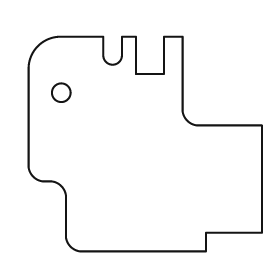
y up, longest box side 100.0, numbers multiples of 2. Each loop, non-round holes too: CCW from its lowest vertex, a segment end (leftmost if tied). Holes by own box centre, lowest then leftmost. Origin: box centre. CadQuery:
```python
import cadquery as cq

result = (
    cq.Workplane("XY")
    .moveTo(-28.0, -46.0)
    .lineTo(26.0, -46.0)
    .lineTo(26.0, -38.0)
    .lineTo(50.0, -38.0)
    .lineTo(50.0, 8.0)
    .lineTo(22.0, 8.0)
    .threePointArc((18.0, 10.0), (16.0, 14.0))
    .lineTo(16.0, 46.0)
    .lineTo(8.0, 46.0)
    .lineTo(8.0, 30.0)
    .lineTo(-4.0, 30.0)
    .lineTo(-4.0, 46.0)
    .lineTo(-10.0, 46.0)
    .lineTo(-10.0, 38.0)
    .threePointArc((-14.0, 34.0), (-18.0, 38.0))
    .lineTo(-18.0, 46.0)
    .lineTo(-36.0, 46.0)
    .threePointArc((-46.0, 42.0), (-50.0, 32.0))
    .lineTo(-50.0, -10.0)
    .threePointArc((-48.0, -14.0), (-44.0, -16.0))
    .lineTo(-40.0, -16.0)
    .threePointArc((-36.0, -18.0), (-34.0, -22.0))
    .lineTo(-34.0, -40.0)
    .threePointArc((-32.0, -44.0), (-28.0, -46.0))
    .close()
    .moveTo(-36.0, 22.0)
    .circle(4.0)
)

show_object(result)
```